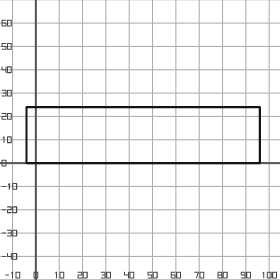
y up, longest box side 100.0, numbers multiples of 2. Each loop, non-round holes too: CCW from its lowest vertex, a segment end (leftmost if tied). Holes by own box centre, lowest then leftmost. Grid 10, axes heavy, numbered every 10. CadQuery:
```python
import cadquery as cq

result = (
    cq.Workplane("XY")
    .moveTo(-4.0, 0.0)
    .lineTo(96.0, 0.0)
    .lineTo(96.0, 24.0)
    .lineTo(-4.0, 24.0)
    .close()
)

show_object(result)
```